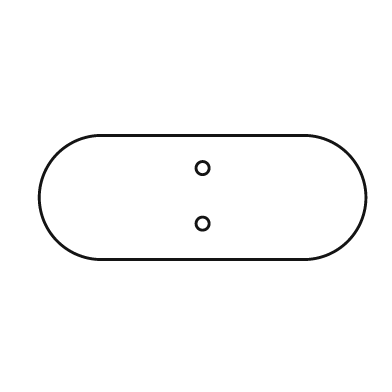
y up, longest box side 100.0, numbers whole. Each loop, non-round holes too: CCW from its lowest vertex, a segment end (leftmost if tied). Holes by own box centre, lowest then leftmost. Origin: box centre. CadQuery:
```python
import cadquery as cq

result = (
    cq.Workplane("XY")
    .moveTo(-31.0, -19.0)
    .lineTo(31.0, -19.0)
    .threePointArc((50.0, 0.0), (31.0, 19.0))
    .lineTo(-31.0, 19.0)
    .threePointArc((-50.0, 0.0), (-31.0, -19.0))
    .close()
    .moveTo(0.0, -8.0)
    .circle(2.0)
    .moveTo(0.0, 9.0)
    .circle(2.0)
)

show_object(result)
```